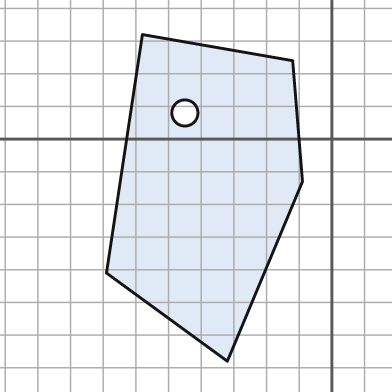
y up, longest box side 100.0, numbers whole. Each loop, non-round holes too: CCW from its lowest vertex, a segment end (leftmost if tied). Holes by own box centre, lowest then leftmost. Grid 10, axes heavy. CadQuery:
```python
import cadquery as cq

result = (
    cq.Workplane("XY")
    .moveTo(-32.0, -68.0)
    .lineTo(-9.0, -13.0)
    .lineTo(-12.0, 24.0)
    .lineTo(-58.0, 32.0)
    .lineTo(-69.0, -41.0)
    .close()
    .moveTo(-45.0, 8.0)
    .circle(4.0)
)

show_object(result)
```